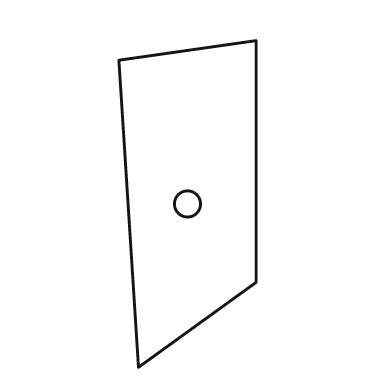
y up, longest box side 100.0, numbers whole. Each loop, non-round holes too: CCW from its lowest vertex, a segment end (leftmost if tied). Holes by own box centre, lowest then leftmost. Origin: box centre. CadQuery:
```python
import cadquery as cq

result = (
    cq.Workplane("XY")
    .moveTo(-15.0, -50.0)
    .lineTo(21.0, -24.0)
    .lineTo(21.0, 50.0)
    .lineTo(-21.0, 44.0)
    .close()
    .moveTo(0.0, 0.0)
    .circle(4.0)
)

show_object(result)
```